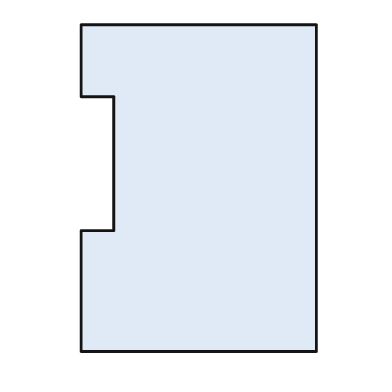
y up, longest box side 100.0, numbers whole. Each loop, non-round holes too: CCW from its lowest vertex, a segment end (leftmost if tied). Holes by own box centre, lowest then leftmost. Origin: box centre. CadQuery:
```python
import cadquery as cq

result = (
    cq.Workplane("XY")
    .moveTo(-36.0, -50.0)
    .lineTo(36.0, -50.0)
    .lineTo(36.0, 50.0)
    .lineTo(-36.0, 50.0)
    .lineTo(-36.0, 28.0)
    .lineTo(-26.0, 28.0)
    .lineTo(-26.0, -13.0)
    .lineTo(-36.0, -13.0)
    .close()
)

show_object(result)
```